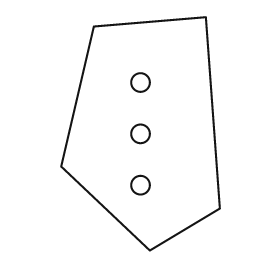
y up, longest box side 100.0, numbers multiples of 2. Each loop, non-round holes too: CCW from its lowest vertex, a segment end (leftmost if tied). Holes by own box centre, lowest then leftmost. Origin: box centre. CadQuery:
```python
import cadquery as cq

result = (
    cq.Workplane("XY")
    .moveTo(4.0, -50.0)
    .lineTo(34.0, -32.0)
    .lineTo(28.0, 50.0)
    .lineTo(-20.0, 46.0)
    .lineTo(-34.0, -14.0)
    .close()
    .moveTo(0.0, -22.0)
    .circle(4.0)
    .moveTo(0.0, 0.0)
    .circle(4.0)
    .moveTo(0.0, 22.0)
    .circle(4.0)
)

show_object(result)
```